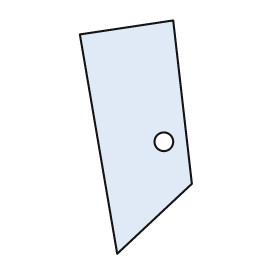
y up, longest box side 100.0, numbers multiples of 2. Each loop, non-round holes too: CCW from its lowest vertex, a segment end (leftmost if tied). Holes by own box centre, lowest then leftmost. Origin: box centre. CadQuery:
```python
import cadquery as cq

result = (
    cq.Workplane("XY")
    .moveTo(-8.0, -50.0)
    .lineTo(24.0, -20.0)
    .lineTo(16.0, 50.0)
    .lineTo(-24.0, 44.0)
    .close()
    .moveTo(12.0, -2.0)
    .circle(4.0)
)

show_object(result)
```